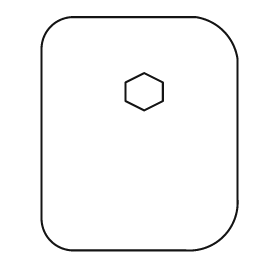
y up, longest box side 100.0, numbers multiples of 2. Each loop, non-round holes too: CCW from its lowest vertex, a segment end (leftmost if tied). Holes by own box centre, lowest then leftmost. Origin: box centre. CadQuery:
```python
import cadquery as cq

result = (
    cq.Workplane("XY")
    .moveTo(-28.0, -50.0)
    .lineTo(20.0, -50.0)
    .threePointArc((36.0, -44.0), (42.0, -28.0))
    .lineTo(42.0, 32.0)
    .threePointArc((36.0, 44.0), (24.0, 50.0))
    .lineTo(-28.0, 50.0)
    .threePointArc((-38.0, 46.0), (-42.0, 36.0))
    .lineTo(-42.0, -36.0)
    .threePointArc((-38.0, -46.0), (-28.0, -50.0))
    .close()
    .moveTo(2.0, 10.0)
    .lineTo(10.0, 14.0)
    .lineTo(10.0, 22.0)
    .lineTo(2.0, 26.0)
    .lineTo(-6.0, 22.0)
    .lineTo(-6.0, 14.0)
    .close()
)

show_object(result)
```